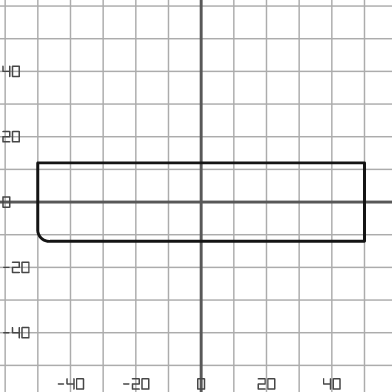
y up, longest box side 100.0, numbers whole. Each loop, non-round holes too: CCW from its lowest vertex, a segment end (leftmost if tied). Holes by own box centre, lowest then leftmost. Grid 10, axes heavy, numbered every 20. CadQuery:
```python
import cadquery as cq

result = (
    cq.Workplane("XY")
    .moveTo(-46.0, -12.0)
    .lineTo(50.0, -12.0)
    .lineTo(50.0, 12.0)
    .lineTo(-50.0, 12.0)
    .lineTo(-50.0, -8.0)
    .threePointArc((-49.0, -11.0), (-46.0, -12.0))
    .close()
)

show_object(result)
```